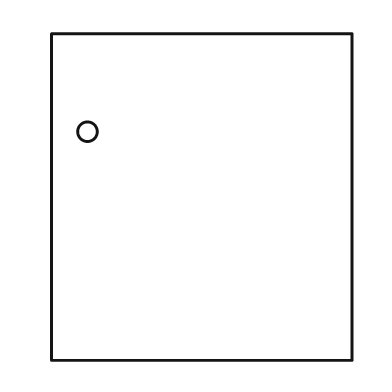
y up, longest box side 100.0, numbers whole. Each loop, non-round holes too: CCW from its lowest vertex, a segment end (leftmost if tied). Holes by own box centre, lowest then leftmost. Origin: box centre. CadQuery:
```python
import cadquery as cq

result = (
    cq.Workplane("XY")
    .moveTo(-46.0, -50.0)
    .lineTo(46.0, -50.0)
    .lineTo(46.0, 50.0)
    .lineTo(-46.0, 50.0)
    .close()
    .moveTo(-35.0, 20.0)
    .circle(3.0)
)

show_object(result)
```